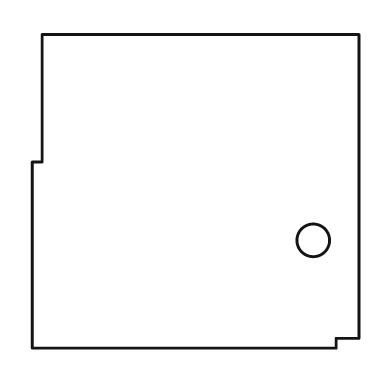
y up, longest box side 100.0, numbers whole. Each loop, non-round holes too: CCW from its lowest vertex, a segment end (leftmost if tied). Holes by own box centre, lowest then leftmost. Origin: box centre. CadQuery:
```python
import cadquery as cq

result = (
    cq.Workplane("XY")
    .moveTo(-50.0, -48.0)
    .lineTo(43.0, -48.0)
    .lineTo(43.0, -45.0)
    .lineTo(50.0, -45.0)
    .lineTo(50.0, 48.0)
    .lineTo(-47.0, 48.0)
    .lineTo(-47.0, 9.0)
    .lineTo(-50.0, 9.0)
    .close()
    .moveTo(36.0, -15.0)
    .circle(5.0)
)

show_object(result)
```